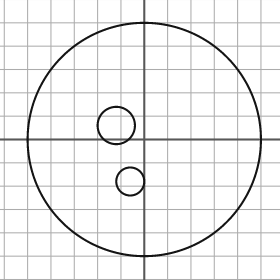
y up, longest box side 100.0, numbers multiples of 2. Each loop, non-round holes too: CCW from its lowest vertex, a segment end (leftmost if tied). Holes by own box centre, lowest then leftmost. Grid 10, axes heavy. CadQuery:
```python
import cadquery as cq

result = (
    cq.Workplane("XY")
    .moveTo(0.0, 0.0)
    .circle(50.0)
    .moveTo(-6.0, -18.0)
    .circle(6.0)
    .moveTo(-12.0, 6.0)
    .circle(8.0)
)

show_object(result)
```